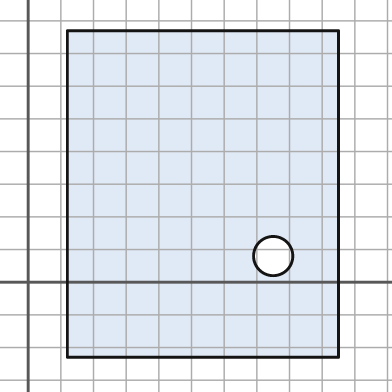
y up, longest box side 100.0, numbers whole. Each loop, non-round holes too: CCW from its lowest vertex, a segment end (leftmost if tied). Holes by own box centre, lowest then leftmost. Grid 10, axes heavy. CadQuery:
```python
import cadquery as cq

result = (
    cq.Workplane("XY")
    .moveTo(12.0, -23.0)
    .lineTo(95.0, -23.0)
    .lineTo(95.0, 77.0)
    .lineTo(12.0, 77.0)
    .close()
    .moveTo(75.0, 8.0)
    .circle(6.0)
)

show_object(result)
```